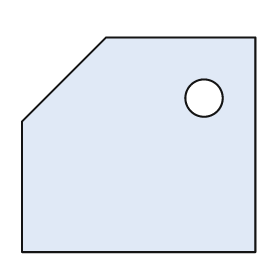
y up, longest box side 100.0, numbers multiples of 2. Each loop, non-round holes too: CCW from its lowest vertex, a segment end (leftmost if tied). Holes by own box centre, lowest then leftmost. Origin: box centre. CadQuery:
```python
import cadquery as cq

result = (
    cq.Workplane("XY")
    .moveTo(-50.0, -46.0)
    .lineTo(50.0, -46.0)
    .lineTo(50.0, 46.0)
    .lineTo(-14.0, 46.0)
    .lineTo(-50.0, 10.0)
    .close()
    .moveTo(28.0, 20.0)
    .circle(8.0)
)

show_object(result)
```